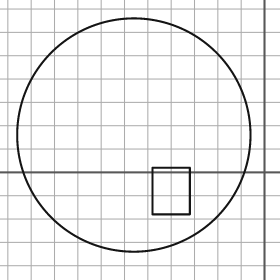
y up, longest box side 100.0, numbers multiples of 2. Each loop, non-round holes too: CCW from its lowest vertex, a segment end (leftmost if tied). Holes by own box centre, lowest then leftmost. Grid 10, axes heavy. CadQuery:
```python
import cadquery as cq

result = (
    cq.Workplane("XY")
    .moveTo(-56.0, 16.0)
    .circle(50.0)
    .moveTo(-48.0, -18.0)
    .lineTo(-32.0, -18.0)
    .lineTo(-32.0, 2.0)
    .lineTo(-48.0, 2.0)
    .close()
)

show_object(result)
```